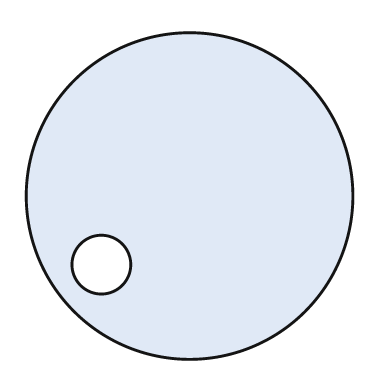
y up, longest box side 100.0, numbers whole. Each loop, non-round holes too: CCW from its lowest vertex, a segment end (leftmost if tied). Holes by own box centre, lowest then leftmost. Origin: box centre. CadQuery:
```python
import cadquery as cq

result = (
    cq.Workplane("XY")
    .moveTo(0.0, 0.0)
    .circle(50.0)
    .moveTo(-27.0, -21.0)
    .circle(9.0)
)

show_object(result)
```